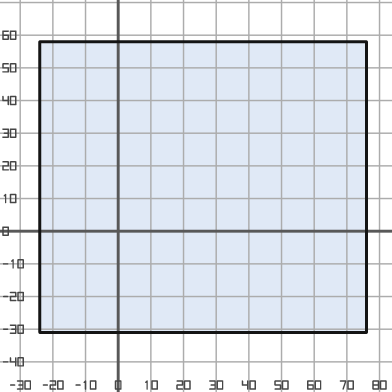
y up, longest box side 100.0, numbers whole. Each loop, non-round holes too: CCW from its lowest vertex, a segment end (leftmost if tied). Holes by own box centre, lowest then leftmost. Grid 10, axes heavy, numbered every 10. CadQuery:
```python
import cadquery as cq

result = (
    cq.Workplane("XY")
    .moveTo(-24.0, -31.0)
    .lineTo(76.0, -31.0)
    .lineTo(76.0, 58.0)
    .lineTo(-24.0, 58.0)
    .close()
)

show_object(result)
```